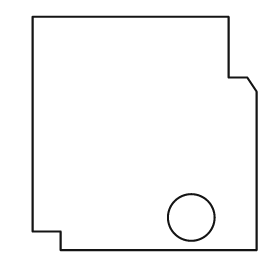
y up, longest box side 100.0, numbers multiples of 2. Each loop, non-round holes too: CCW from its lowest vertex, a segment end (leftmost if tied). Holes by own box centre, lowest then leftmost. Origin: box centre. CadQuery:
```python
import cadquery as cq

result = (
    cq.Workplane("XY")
    .moveTo(-36.0, -50.0)
    .lineTo(48.0, -50.0)
    .lineTo(48.0, 18.0)
    .lineTo(44.0, 24.0)
    .lineTo(36.0, 24.0)
    .lineTo(36.0, 50.0)
    .lineTo(-48.0, 50.0)
    .lineTo(-48.0, -42.0)
    .lineTo(-36.0, -42.0)
    .close()
    .moveTo(20.0, -36.0)
    .circle(10.0)
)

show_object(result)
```